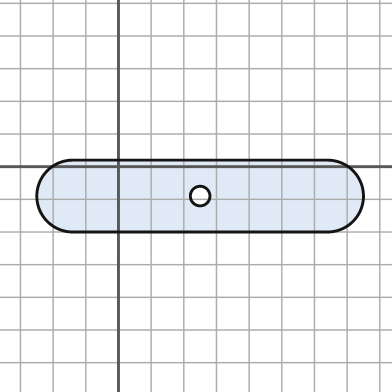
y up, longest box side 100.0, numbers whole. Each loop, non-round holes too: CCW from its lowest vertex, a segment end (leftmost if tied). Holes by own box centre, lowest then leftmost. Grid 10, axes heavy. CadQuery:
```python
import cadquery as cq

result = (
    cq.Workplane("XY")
    .moveTo(-14.0, -20.0)
    .lineTo(64.0, -20.0)
    .threePointArc((75.0, -9.0), (64.0, 2.0))
    .lineTo(-14.0, 2.0)
    .threePointArc((-25.0, -9.0), (-14.0, -20.0))
    .close()
    .moveTo(25.0, -9.0)
    .circle(3.0)
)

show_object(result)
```